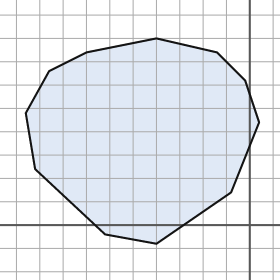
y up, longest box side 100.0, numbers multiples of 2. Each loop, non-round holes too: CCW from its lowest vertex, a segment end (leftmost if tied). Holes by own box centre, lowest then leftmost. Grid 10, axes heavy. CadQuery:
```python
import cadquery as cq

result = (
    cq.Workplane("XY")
    .moveTo(-40.0, -8.0)
    .lineTo(-8.0, 14.0)
    .lineTo(4.0, 44.0)
    .lineTo(-2.0, 62.0)
    .lineTo(-14.0, 74.0)
    .lineTo(-40.0, 80.0)
    .lineTo(-70.0, 74.0)
    .lineTo(-86.0, 66.0)
    .lineTo(-96.0, 48.0)
    .lineTo(-92.0, 24.0)
    .lineTo(-62.0, -4.0)
    .close()
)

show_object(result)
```